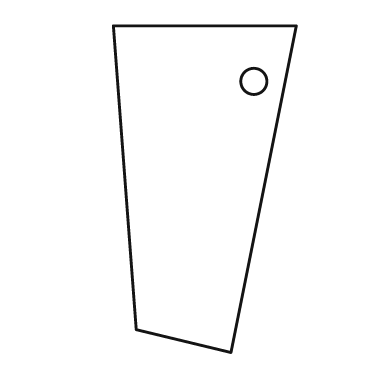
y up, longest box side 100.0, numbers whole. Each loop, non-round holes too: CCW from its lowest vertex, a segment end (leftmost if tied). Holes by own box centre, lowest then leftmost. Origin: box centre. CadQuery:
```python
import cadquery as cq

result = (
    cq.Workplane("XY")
    .moveTo(8.0, -50.0)
    .lineTo(28.0, 50.0)
    .lineTo(-28.0, 50.0)
    .lineTo(-21.0, -43.0)
    .close()
    .moveTo(15.0, 33.0)
    .circle(4.0)
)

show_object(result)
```